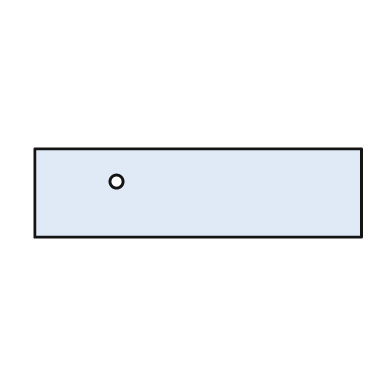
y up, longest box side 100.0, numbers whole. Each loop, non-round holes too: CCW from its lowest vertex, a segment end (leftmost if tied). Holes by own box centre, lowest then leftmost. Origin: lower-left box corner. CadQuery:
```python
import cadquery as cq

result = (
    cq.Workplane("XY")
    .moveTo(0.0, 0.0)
    .lineTo(100.0, 0.0)
    .lineTo(100.0, 27.0)
    .lineTo(0.0, 27.0)
    .close()
    .moveTo(25.0, 17.0)
    .circle(2.0)
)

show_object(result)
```